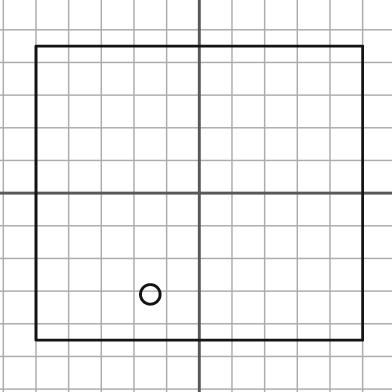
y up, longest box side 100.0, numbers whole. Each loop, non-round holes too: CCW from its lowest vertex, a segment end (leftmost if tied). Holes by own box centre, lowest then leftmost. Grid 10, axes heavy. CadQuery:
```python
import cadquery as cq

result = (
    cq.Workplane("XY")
    .moveTo(-50.0, -45.0)
    .lineTo(50.0, -45.0)
    .lineTo(50.0, 45.0)
    .lineTo(-50.0, 45.0)
    .close()
    .moveTo(-15.0, -31.0)
    .circle(3.0)
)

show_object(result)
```